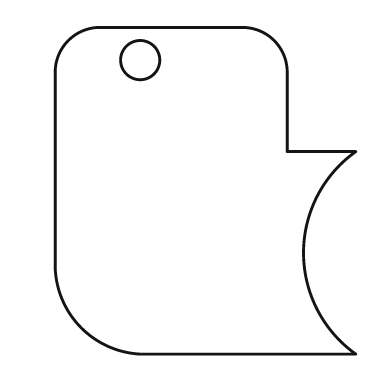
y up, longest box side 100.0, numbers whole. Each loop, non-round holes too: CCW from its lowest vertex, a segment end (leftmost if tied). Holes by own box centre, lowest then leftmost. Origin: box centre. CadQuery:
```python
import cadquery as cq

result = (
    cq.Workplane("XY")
    .moveTo(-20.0, -50.0)
    .lineTo(46.0, -50.0)
    .threePointArc((30.0, -19.0), (46.0, 12.0))
    .lineTo(25.0, 12.0)
    .lineTo(25.0, 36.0)
    .threePointArc((21.0, 46.0), (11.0, 50.0))
    .lineTo(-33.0, 50.0)
    .threePointArc((-42.0, 46.0), (-46.0, 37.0))
    .lineTo(-46.0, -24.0)
    .threePointArc((-38.0, -42.0), (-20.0, -50.0))
    .close()
    .moveTo(-20.0, 40.0)
    .circle(6.0)
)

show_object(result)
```